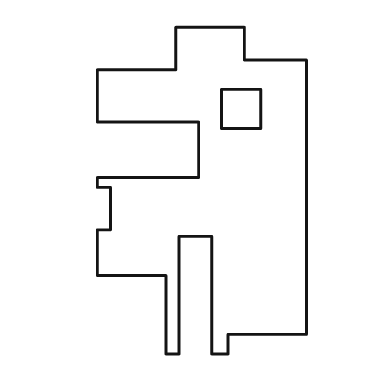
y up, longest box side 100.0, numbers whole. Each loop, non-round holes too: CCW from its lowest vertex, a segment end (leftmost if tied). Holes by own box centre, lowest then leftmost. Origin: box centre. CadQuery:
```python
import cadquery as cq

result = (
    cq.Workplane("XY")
    .moveTo(-11.0, -50.0)
    .lineTo(-7.0, -50.0)
    .lineTo(-7.0, -14.0)
    .lineTo(3.0, -14.0)
    .lineTo(3.0, -50.0)
    .lineTo(8.0, -50.0)
    .lineTo(8.0, -44.0)
    .lineTo(32.0, -44.0)
    .lineTo(32.0, 40.0)
    .lineTo(13.0, 40.0)
    .lineTo(13.0, 50.0)
    .lineTo(-8.0, 50.0)
    .lineTo(-8.0, 37.0)
    .lineTo(-32.0, 37.0)
    .lineTo(-32.0, 21.0)
    .lineTo(-1.0, 21.0)
    .lineTo(-1.0, 4.0)
    .lineTo(-32.0, 4.0)
    .lineTo(-32.0, 1.0)
    .lineTo(-28.0, 1.0)
    .lineTo(-28.0, -12.0)
    .lineTo(-32.0, -12.0)
    .lineTo(-32.0, -26.0)
    .lineTo(-11.0, -26.0)
    .close()
    .moveTo(6.0, 19.0)
    .lineTo(18.0, 19.0)
    .lineTo(18.0, 31.0)
    .lineTo(6.0, 31.0)
    .close()
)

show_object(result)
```